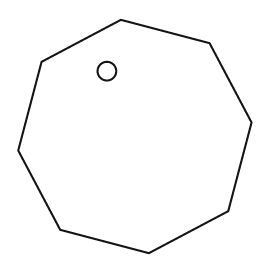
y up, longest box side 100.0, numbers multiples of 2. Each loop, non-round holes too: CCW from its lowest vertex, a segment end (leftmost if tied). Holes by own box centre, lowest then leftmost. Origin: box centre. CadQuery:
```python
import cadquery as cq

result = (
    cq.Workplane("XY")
    .moveTo(6.0, -50.0)
    .lineTo(40.0, -32.0)
    .lineTo(50.0, 6.0)
    .lineTo(32.0, 40.0)
    .lineTo(-6.0, 50.0)
    .lineTo(-40.0, 32.0)
    .lineTo(-50.0, -6.0)
    .lineTo(-32.0, -40.0)
    .close()
    .moveTo(-12.0, 28.0)
    .circle(4.0)
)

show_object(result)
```